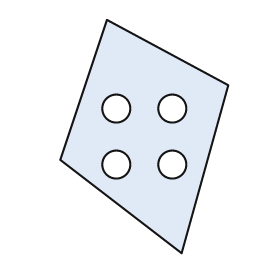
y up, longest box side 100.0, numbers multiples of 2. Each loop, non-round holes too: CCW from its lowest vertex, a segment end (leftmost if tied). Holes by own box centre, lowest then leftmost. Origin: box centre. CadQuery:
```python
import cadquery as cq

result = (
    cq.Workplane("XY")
    .moveTo(16.0, -50.0)
    .lineTo(36.0, 22.0)
    .lineTo(-16.0, 50.0)
    .lineTo(-36.0, -10.0)
    .close()
    .moveTo(-12.0, -12.0)
    .circle(6.0)
    .moveTo(12.0, -12.0)
    .circle(6.0)
    .moveTo(-12.0, 12.0)
    .circle(6.0)
    .moveTo(12.0, 12.0)
    .circle(6.0)
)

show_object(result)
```